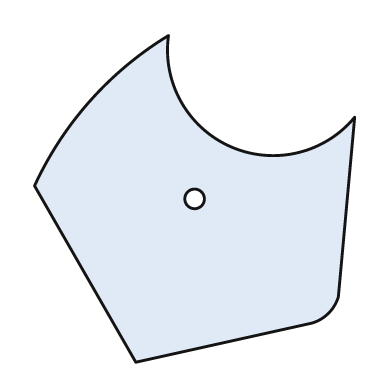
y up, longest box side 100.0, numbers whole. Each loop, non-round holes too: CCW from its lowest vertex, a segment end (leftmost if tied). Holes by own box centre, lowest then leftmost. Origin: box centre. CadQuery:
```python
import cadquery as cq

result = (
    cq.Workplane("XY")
    .moveTo(-18.0, -50.0)
    .lineTo(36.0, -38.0)
    .threePointArc((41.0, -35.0), (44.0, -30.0))
    .lineTo(49.0, 25.0)
    .threePointArc((11.0, 16.0), (-8.0, 50.0))
    .threePointArc((-32.0, 30.0), (-49.0, 4.0))
    .close()
    .moveTo(0.0, 0.0)
    .circle(3.0)
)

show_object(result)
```